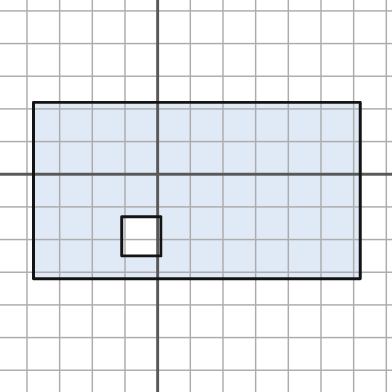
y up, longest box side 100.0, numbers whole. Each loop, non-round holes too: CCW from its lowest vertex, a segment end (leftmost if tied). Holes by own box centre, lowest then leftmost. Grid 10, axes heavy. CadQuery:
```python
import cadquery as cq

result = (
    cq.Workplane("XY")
    .moveTo(-38.0, -32.0)
    .lineTo(62.0, -32.0)
    .lineTo(62.0, 22.0)
    .lineTo(-38.0, 22.0)
    .close()
    .moveTo(-11.0, -25.0)
    .lineTo(1.0, -25.0)
    .lineTo(1.0, -13.0)
    .lineTo(-11.0, -13.0)
    .close()
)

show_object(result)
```